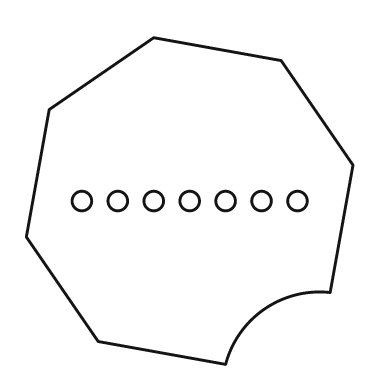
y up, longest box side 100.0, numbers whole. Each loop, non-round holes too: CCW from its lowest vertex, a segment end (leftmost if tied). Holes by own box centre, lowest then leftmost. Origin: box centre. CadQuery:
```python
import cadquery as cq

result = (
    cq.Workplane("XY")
    .moveTo(11.0, -50.0)
    .threePointArc((23.0, -33.0), (43.0, -28.0))
    .lineTo(50.0, 11.0)
    .lineTo(28.0, 43.0)
    .lineTo(-11.0, 50.0)
    .lineTo(-43.0, 28.0)
    .lineTo(-50.0, -11.0)
    .lineTo(-28.0, -43.0)
    .close()
    .moveTo(-33.0, 0.0)
    .circle(3.0)
    .moveTo(-22.0, 0.0)
    .circle(3.0)
    .moveTo(-11.0, 0.0)
    .circle(3.0)
    .moveTo(0.0, 0.0)
    .circle(3.0)
    .moveTo(11.0, 0.0)
    .circle(3.0)
    .moveTo(22.0, 0.0)
    .circle(3.0)
    .moveTo(33.0, 0.0)
    .circle(3.0)
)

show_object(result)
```